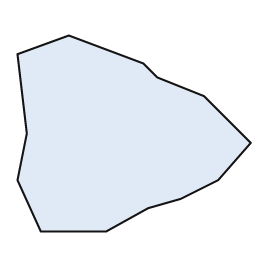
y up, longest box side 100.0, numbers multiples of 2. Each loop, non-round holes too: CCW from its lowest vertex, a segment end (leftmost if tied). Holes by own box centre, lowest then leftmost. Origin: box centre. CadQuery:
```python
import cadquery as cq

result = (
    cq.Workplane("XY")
    .moveTo(-40.0, -42.0)
    .lineTo(-12.0, -42.0)
    .lineTo(6.0, -32.0)
    .lineTo(20.0, -28.0)
    .lineTo(36.0, -20.0)
    .lineTo(50.0, -4.0)
    .lineTo(30.0, 16.0)
    .lineTo(10.0, 24.0)
    .lineTo(4.0, 30.0)
    .lineTo(-28.0, 42.0)
    .lineTo(-50.0, 34.0)
    .lineTo(-46.0, 0.0)
    .lineTo(-50.0, -20.0)
    .close()
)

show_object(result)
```